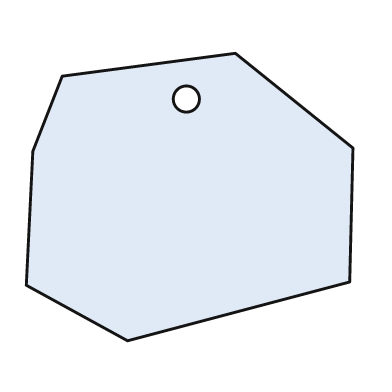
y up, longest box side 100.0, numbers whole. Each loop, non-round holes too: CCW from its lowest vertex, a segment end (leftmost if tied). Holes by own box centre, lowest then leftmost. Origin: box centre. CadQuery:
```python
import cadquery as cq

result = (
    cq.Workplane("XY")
    .moveTo(-19.0, -44.0)
    .lineTo(49.0, -26.0)
    .lineTo(50.0, 15.0)
    .lineTo(14.0, 44.0)
    .lineTo(-39.0, 37.0)
    .lineTo(-48.0, 14.0)
    .lineTo(-50.0, -27.0)
    .close()
    .moveTo(-1.0, 30.0)
    .circle(4.0)
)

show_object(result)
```